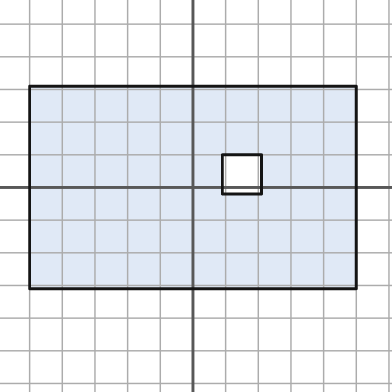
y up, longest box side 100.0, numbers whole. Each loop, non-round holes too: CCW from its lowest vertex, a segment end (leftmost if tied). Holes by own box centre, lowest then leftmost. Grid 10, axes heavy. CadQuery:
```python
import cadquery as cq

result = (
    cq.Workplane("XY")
    .moveTo(-50.0, -31.0)
    .lineTo(50.0, -31.0)
    .lineTo(50.0, 31.0)
    .lineTo(-50.0, 31.0)
    .close()
    .moveTo(9.0, -2.0)
    .lineTo(21.0, -2.0)
    .lineTo(21.0, 10.0)
    .lineTo(9.0, 10.0)
    .close()
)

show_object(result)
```